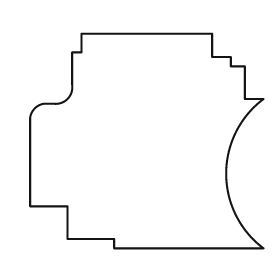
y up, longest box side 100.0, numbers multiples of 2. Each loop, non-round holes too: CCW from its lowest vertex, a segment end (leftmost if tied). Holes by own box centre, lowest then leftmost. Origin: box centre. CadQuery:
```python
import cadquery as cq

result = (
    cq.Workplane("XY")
    .moveTo(-14.0, -46.0)
    .lineTo(50.0, -46.0)
    .threePointArc((34.0, -14.0), (50.0, 18.0))
    .lineTo(42.0, 18.0)
    .lineTo(42.0, 32.0)
    .lineTo(36.0, 32.0)
    .lineTo(36.0, 36.0)
    .lineTo(28.0, 36.0)
    .lineTo(28.0, 46.0)
    .lineTo(-28.0, 46.0)
    .lineTo(-28.0, 38.0)
    .lineTo(-32.0, 38.0)
    .lineTo(-32.0, 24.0)
    .threePointArc((-34.0, 18.0), (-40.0, 16.0))
    .lineTo(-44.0, 16.0)
    .threePointArc((-48.0, 14.0), (-50.0, 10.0))
    .lineTo(-50.0, -28.0)
    .lineTo(-34.0, -28.0)
    .lineTo(-34.0, -42.0)
    .lineTo(-14.0, -42.0)
    .close()
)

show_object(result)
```